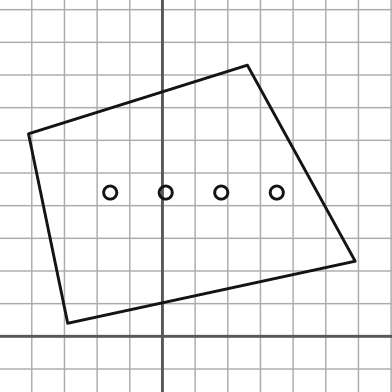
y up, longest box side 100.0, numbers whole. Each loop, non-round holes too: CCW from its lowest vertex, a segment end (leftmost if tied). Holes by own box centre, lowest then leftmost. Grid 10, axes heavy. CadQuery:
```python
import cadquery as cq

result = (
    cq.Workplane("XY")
    .moveTo(-29.0, 4.0)
    .lineTo(59.0, 23.0)
    .lineTo(26.0, 83.0)
    .lineTo(-41.0, 62.0)
    .close()
    .moveTo(-16.0, 44.0)
    .circle(2.0)
    .moveTo(1.0, 44.0)
    .circle(2.0)
    .moveTo(18.0, 44.0)
    .circle(2.0)
    .moveTo(35.0, 44.0)
    .circle(2.0)
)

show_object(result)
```